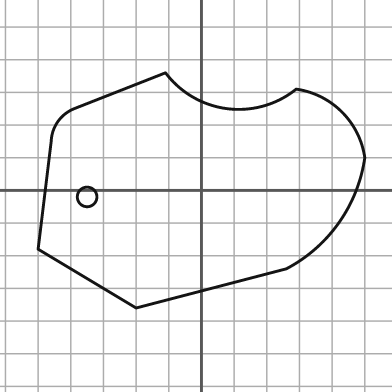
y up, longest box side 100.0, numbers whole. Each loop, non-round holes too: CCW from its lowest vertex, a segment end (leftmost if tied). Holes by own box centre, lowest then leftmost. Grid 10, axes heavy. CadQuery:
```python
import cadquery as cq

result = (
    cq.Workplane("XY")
    .moveTo(-20.0, -36.0)
    .lineTo(26.0, -24.0)
    .threePointArc((42.0, -10.0), (50.0, 10.0))
    .threePointArc((43.0, 24.0), (29.0, 31.0))
    .threePointArc((8.0, 25.0), (-11.0, 36.0))
    .lineTo(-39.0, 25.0)
    .threePointArc((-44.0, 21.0), (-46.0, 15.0))
    .lineTo(-50.0, -18.0)
    .close()
    .moveTo(-35.0, -2.0)
    .circle(3.0)
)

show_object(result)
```